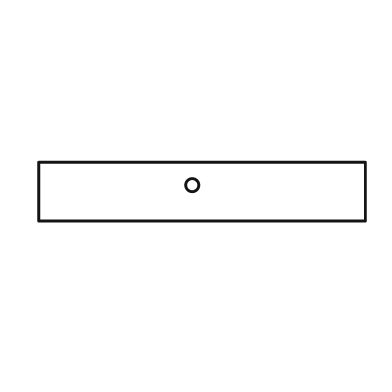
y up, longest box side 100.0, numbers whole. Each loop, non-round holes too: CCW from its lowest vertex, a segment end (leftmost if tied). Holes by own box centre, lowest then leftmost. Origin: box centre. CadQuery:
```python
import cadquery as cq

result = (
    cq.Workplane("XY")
    .moveTo(-50.0, -9.0)
    .lineTo(50.0, -9.0)
    .lineTo(50.0, 9.0)
    .lineTo(-50.0, 9.0)
    .close()
    .moveTo(-3.0, 2.0)
    .circle(2.0)
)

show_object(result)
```